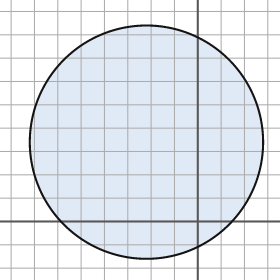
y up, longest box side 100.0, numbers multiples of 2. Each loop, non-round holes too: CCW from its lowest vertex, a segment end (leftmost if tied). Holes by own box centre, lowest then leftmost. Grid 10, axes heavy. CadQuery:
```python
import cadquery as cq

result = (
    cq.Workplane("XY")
    .moveTo(-22.0, 34.0)
    .circle(50.0)
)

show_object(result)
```